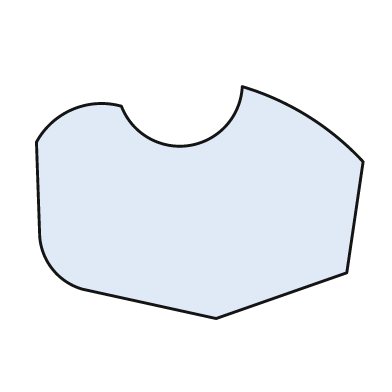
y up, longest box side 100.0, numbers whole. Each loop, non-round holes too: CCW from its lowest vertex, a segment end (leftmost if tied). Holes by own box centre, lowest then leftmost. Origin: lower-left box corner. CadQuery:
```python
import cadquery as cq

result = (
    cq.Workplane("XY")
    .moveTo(55.0, 0.0)
    .lineTo(95.0, 14.0)
    .lineTo(100.0, 48.0)
    .threePointArc((83.0, 62.0), (63.0, 71.0))
    .threePointArc((47.0, 53.0), (26.0, 65.0))
    .threePointArc((11.0, 64.0), (0.0, 54.0))
    .lineTo(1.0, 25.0)
    .threePointArc((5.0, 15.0), (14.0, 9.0))
    .close()
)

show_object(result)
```